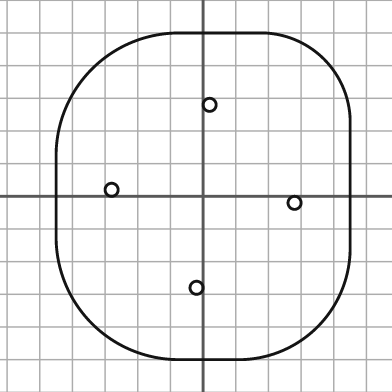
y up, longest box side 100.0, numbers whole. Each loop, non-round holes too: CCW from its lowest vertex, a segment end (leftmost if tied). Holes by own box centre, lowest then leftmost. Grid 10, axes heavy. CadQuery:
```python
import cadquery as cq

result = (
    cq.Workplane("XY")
    .moveTo(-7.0, -50.0)
    .lineTo(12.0, -50.0)
    .threePointArc((35.0, -40.0), (45.0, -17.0))
    .lineTo(45.0, 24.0)
    .threePointArc((37.0, 42.0), (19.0, 50.0))
    .lineTo(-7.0, 50.0)
    .threePointArc((-34.0, 39.0), (-45.0, 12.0))
    .lineTo(-45.0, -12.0)
    .threePointArc((-34.0, -39.0), (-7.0, -50.0))
    .close()
    .moveTo(-2.0, -28.0)
    .circle(2.0)
    .moveTo(28.0, -2.0)
    .circle(2.0)
    .moveTo(-28.0, 2.0)
    .circle(2.0)
    .moveTo(2.0, 28.0)
    .circle(2.0)
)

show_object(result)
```